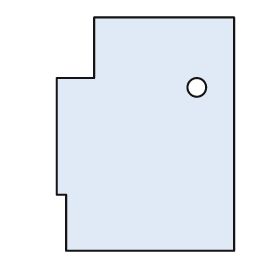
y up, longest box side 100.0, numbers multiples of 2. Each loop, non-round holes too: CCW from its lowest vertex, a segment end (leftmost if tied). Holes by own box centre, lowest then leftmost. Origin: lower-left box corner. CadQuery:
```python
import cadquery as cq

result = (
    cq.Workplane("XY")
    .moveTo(4.0, 0.0)
    .lineTo(76.0, 0.0)
    .lineTo(76.0, 100.0)
    .lineTo(16.0, 100.0)
    .lineTo(16.0, 74.0)
    .lineTo(0.0, 74.0)
    .lineTo(0.0, 24.0)
    .lineTo(4.0, 24.0)
    .close()
    .moveTo(60.0, 70.0)
    .circle(4.0)
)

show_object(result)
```